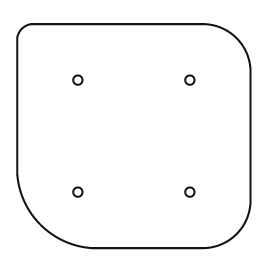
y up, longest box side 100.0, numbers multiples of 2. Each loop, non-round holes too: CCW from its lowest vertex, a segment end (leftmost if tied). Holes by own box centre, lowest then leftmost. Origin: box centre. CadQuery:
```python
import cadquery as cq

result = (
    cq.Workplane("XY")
    .moveTo(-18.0, -48.0)
    .lineTo(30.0, -48.0)
    .threePointArc((44.0, -42.0), (50.0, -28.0))
    .lineTo(50.0, 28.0)
    .threePointArc((44.0, 42.0), (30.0, 48.0))
    .lineTo(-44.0, 48.0)
    .threePointArc((-48.0, 46.0), (-50.0, 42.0))
    .lineTo(-50.0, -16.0)
    .threePointArc((-40.0, -38.0), (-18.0, -48.0))
    .close()
    .moveTo(-24.0, -24.0)
    .circle(2.0)
    .moveTo(24.0, -24.0)
    .circle(2.0)
    .moveTo(-24.0, 24.0)
    .circle(2.0)
    .moveTo(24.0, 24.0)
    .circle(2.0)
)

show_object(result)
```